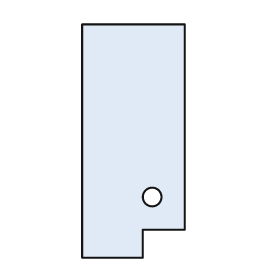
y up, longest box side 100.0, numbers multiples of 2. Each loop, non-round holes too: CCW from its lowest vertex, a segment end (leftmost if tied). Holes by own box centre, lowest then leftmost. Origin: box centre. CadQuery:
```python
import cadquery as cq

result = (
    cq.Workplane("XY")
    .moveTo(-22.0, -50.0)
    .lineTo(4.0, -50.0)
    .lineTo(4.0, -38.0)
    .lineTo(22.0, -38.0)
    .lineTo(22.0, 50.0)
    .lineTo(-22.0, 50.0)
    .close()
    .moveTo(8.0, -24.0)
    .circle(4.0)
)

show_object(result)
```